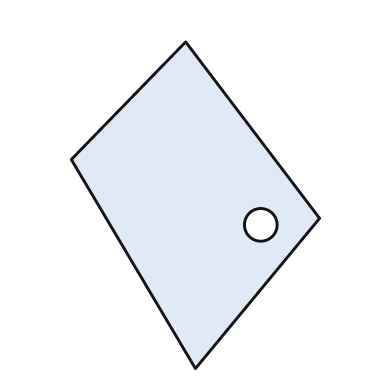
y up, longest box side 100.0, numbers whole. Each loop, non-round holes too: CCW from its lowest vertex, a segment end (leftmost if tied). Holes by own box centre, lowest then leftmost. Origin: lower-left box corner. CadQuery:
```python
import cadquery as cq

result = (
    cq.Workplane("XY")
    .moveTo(38.0, 0.0)
    .lineTo(76.0, 46.0)
    .lineTo(35.0, 100.0)
    .lineTo(0.0, 64.0)
    .close()
    .moveTo(58.0, 44.0)
    .circle(5.0)
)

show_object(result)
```